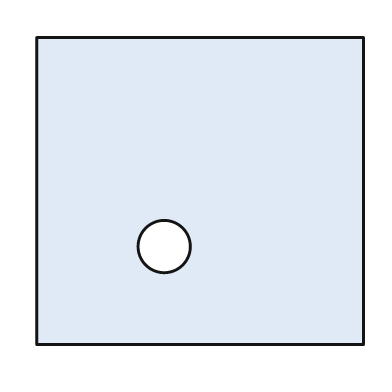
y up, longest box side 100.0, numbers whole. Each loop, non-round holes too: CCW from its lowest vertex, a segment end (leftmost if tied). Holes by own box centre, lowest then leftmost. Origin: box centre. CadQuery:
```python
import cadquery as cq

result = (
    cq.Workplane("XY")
    .moveTo(-50.0, -47.0)
    .lineTo(50.0, -47.0)
    .lineTo(50.0, 47.0)
    .lineTo(-50.0, 47.0)
    .close()
    .moveTo(-11.0, -17.0)
    .circle(8.0)
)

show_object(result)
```